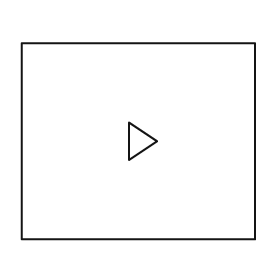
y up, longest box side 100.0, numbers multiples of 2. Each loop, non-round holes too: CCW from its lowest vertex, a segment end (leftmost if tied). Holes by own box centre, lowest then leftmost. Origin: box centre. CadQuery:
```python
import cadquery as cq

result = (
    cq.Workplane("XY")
    .moveTo(-50.0, -42.0)
    .lineTo(50.0, -42.0)
    .lineTo(50.0, 42.0)
    .lineTo(-50.0, 42.0)
    .close()
    .moveTo(-4.0, -8.0)
    .lineTo(8.0, 0.0)
    .lineTo(-4.0, 8.0)
    .close()
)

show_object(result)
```